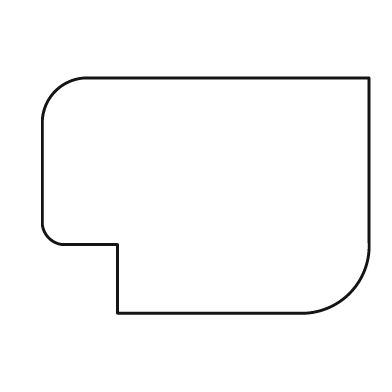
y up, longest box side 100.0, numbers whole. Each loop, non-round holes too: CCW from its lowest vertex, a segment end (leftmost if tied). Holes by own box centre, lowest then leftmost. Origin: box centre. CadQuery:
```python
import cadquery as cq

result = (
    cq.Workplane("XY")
    .moveTo(-27.0, -36.0)
    .lineTo(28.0, -36.0)
    .threePointArc((44.0, -30.0), (50.0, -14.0))
    .lineTo(50.0, 36.0)
    .lineTo(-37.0, 36.0)
    .threePointArc((-46.0, 32.0), (-50.0, 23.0))
    .lineTo(-50.0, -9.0)
    .threePointArc((-48.0, -13.0), (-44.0, -15.0))
    .lineTo(-27.0, -15.0)
    .close()
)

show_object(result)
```